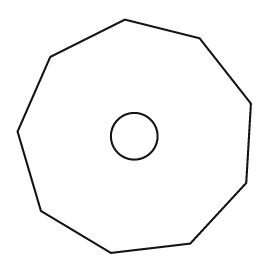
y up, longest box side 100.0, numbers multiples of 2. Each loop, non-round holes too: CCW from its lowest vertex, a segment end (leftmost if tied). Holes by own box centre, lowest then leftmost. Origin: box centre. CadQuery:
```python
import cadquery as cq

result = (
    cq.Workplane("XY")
    .moveTo(-10.0, -50.0)
    .lineTo(24.0, -46.0)
    .lineTo(48.0, -20.0)
    .lineTo(50.0, 14.0)
    .lineTo(28.0, 42.0)
    .lineTo(-4.0, 50.0)
    .lineTo(-36.0, 34.0)
    .lineTo(-50.0, 2.0)
    .lineTo(-40.0, -32.0)
    .close()
    .moveTo(0.0, 0.0)
    .circle(10.0)
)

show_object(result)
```